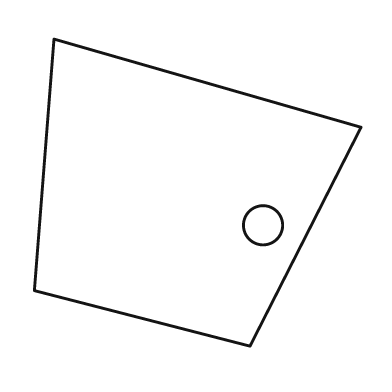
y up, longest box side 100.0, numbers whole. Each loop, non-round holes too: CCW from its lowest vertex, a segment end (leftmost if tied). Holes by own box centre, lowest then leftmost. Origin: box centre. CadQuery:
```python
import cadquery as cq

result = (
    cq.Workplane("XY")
    .moveTo(16.0, -47.0)
    .lineTo(50.0, 20.0)
    .lineTo(-44.0, 47.0)
    .lineTo(-50.0, -30.0)
    .close()
    .moveTo(20.0, -10.0)
    .circle(6.0)
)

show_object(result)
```